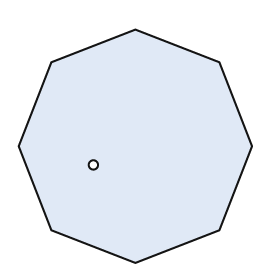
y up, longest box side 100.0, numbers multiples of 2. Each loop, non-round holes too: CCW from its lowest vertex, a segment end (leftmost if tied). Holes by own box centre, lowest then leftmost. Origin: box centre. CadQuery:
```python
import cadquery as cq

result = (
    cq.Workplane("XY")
    .moveTo(0.0, -50.0)
    .lineTo(36.0, -36.0)
    .lineTo(50.0, 0.0)
    .lineTo(36.0, 36.0)
    .lineTo(0.0, 50.0)
    .lineTo(-36.0, 36.0)
    .lineTo(-50.0, 0.0)
    .lineTo(-36.0, -36.0)
    .close()
    .moveTo(-18.0, -8.0)
    .circle(2.0)
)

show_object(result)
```